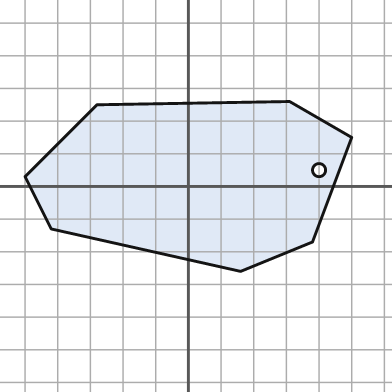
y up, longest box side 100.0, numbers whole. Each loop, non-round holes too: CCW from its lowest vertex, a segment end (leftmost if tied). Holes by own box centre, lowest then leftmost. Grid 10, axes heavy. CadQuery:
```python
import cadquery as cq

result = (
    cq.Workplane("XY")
    .moveTo(16.0, -26.0)
    .lineTo(38.0, -17.0)
    .lineTo(50.0, 15.0)
    .lineTo(31.0, 26.0)
    .lineTo(-28.0, 25.0)
    .lineTo(-50.0, 3.0)
    .lineTo(-42.0, -13.0)
    .close()
    .moveTo(40.0, 5.0)
    .circle(2.0)
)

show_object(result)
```